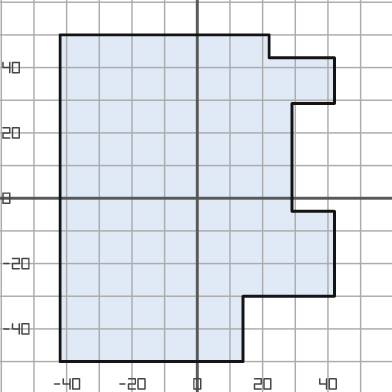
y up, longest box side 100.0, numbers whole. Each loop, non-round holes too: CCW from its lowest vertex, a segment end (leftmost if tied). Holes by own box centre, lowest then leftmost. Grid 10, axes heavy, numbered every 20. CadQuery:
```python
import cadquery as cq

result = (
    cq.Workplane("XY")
    .moveTo(-42.0, -50.0)
    .lineTo(14.0, -50.0)
    .lineTo(14.0, -30.0)
    .lineTo(42.0, -30.0)
    .lineTo(42.0, -4.0)
    .lineTo(29.0, -4.0)
    .lineTo(29.0, 29.0)
    .lineTo(42.0, 29.0)
    .lineTo(42.0, 43.0)
    .lineTo(22.0, 43.0)
    .lineTo(22.0, 50.0)
    .lineTo(-42.0, 50.0)
    .close()
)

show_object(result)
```